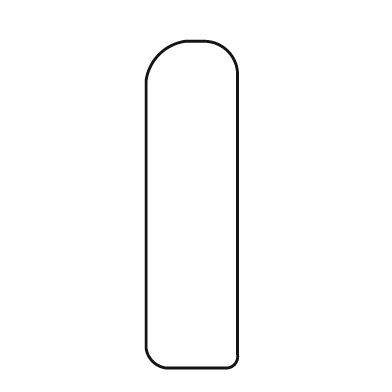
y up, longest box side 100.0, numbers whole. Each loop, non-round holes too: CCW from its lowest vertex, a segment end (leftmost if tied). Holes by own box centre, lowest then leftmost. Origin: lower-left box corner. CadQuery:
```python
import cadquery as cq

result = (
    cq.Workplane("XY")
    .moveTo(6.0, 0.0)
    .lineTo(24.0, 0.0)
    .threePointArc((27.0, 1.0), (28.0, 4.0))
    .lineTo(28.0, 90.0)
    .threePointArc((25.0, 97.0), (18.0, 100.0))
    .lineTo(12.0, 100.0)
    .threePointArc((4.0, 96.0), (0.0, 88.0))
    .lineTo(0.0, 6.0)
    .threePointArc((2.0, 2.0), (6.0, 0.0))
    .close()
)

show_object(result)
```